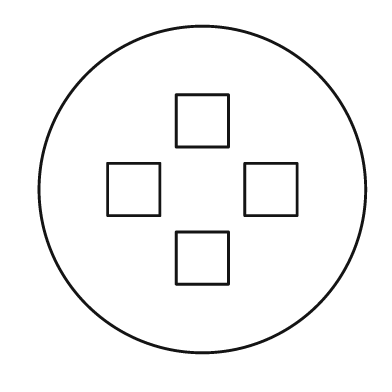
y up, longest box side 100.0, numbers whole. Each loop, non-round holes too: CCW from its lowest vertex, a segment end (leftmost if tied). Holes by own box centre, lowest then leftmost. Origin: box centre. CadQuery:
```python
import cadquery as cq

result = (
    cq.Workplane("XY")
    .moveTo(0.0, 0.0)
    .circle(50.0)
    .moveTo(-8.0, -29.0)
    .lineTo(8.0, -29.0)
    .lineTo(8.0, -13.0)
    .lineTo(-8.0, -13.0)
    .close()
    .moveTo(-29.0, -8.0)
    .lineTo(-13.0, -8.0)
    .lineTo(-13.0, 8.0)
    .lineTo(-29.0, 8.0)
    .close()
    .moveTo(13.0, -8.0)
    .lineTo(29.0, -8.0)
    .lineTo(29.0, 8.0)
    .lineTo(13.0, 8.0)
    .close()
    .moveTo(-8.0, 13.0)
    .lineTo(8.0, 13.0)
    .lineTo(8.0, 29.0)
    .lineTo(-8.0, 29.0)
    .close()
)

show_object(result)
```